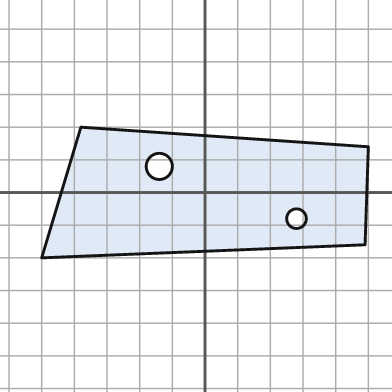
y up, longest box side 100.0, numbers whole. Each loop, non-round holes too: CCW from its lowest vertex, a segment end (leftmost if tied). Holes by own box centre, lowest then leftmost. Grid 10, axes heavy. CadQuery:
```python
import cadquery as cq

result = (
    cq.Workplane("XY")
    .moveTo(-50.0, -20.0)
    .lineTo(49.0, -16.0)
    .lineTo(50.0, 14.0)
    .lineTo(-38.0, 20.0)
    .close()
    .moveTo(28.0, -8.0)
    .circle(3.0)
    .moveTo(-14.0, 8.0)
    .circle(4.0)
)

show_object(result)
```